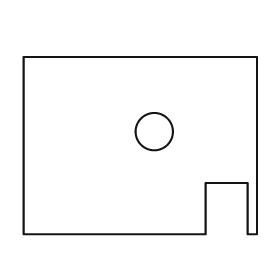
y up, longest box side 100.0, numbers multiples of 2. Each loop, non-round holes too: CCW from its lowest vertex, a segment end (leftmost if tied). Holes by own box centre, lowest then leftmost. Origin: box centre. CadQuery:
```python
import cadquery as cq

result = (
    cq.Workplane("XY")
    .moveTo(-50.0, -38.0)
    .lineTo(28.0, -38.0)
    .lineTo(28.0, -16.0)
    .lineTo(46.0, -16.0)
    .lineTo(46.0, -38.0)
    .lineTo(50.0, -38.0)
    .lineTo(50.0, 38.0)
    .lineTo(-50.0, 38.0)
    .close()
    .moveTo(6.0, 6.0)
    .circle(8.0)
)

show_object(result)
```